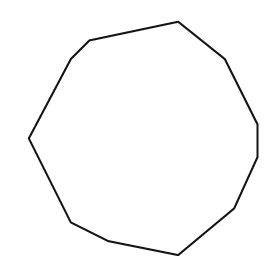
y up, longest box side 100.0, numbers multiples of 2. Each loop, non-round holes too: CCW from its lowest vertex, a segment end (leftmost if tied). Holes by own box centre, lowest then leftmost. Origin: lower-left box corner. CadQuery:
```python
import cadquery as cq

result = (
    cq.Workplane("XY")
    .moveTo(64.0, 0.0)
    .lineTo(88.0, 20.0)
    .lineTo(98.0, 42.0)
    .lineTo(98.0, 56.0)
    .lineTo(84.0, 84.0)
    .lineTo(64.0, 100.0)
    .lineTo(26.0, 92.0)
    .lineTo(18.0, 84.0)
    .lineTo(0.0, 50.0)
    .lineTo(18.0, 14.0)
    .lineTo(34.0, 6.0)
    .close()
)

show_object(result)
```